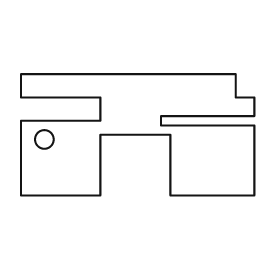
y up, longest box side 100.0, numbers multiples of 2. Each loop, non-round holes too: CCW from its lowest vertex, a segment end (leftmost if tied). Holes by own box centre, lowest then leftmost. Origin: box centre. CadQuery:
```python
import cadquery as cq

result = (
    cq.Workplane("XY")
    .moveTo(-50.0, -26.0)
    .lineTo(-16.0, -26.0)
    .lineTo(-16.0, 0.0)
    .lineTo(14.0, 0.0)
    .lineTo(14.0, -26.0)
    .lineTo(50.0, -26.0)
    .lineTo(50.0, 4.0)
    .lineTo(10.0, 4.0)
    .lineTo(10.0, 8.0)
    .lineTo(50.0, 8.0)
    .lineTo(50.0, 16.0)
    .lineTo(42.0, 16.0)
    .lineTo(42.0, 26.0)
    .lineTo(-50.0, 26.0)
    .lineTo(-50.0, 16.0)
    .lineTo(-16.0, 16.0)
    .lineTo(-16.0, 6.0)
    .lineTo(-50.0, 6.0)
    .close()
    .moveTo(-40.0, -2.0)
    .circle(4.0)
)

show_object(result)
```